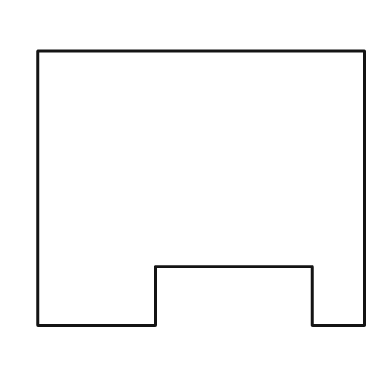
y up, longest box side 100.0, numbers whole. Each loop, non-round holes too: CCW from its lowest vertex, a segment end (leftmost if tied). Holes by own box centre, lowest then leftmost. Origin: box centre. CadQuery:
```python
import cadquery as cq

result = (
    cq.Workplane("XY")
    .moveTo(-50.0, -42.0)
    .lineTo(-14.0, -42.0)
    .lineTo(-14.0, -24.0)
    .lineTo(34.0, -24.0)
    .lineTo(34.0, -42.0)
    .lineTo(50.0, -42.0)
    .lineTo(50.0, 42.0)
    .lineTo(-50.0, 42.0)
    .close()
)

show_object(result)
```